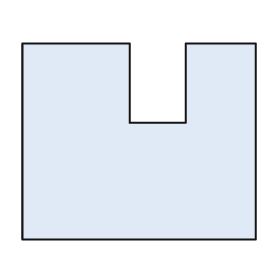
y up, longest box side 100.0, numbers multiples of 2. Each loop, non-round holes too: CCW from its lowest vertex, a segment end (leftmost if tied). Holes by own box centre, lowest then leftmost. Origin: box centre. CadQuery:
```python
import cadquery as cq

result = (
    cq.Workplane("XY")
    .moveTo(-50.0, -42.0)
    .lineTo(50.0, -42.0)
    .lineTo(50.0, 42.0)
    .lineTo(20.0, 42.0)
    .lineTo(20.0, 8.0)
    .lineTo(-4.0, 8.0)
    .lineTo(-4.0, 42.0)
    .lineTo(-50.0, 42.0)
    .close()
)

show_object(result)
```